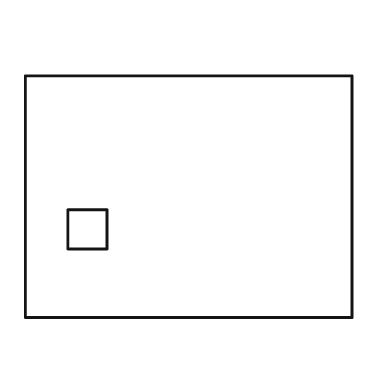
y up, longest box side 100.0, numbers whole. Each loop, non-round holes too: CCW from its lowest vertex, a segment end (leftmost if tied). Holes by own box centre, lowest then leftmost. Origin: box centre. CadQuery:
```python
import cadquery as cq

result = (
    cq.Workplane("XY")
    .moveTo(-50.0, -37.0)
    .lineTo(50.0, -37.0)
    .lineTo(50.0, 37.0)
    .lineTo(-50.0, 37.0)
    .close()
    .moveTo(-37.0, -16.0)
    .lineTo(-25.0, -16.0)
    .lineTo(-25.0, -4.0)
    .lineTo(-37.0, -4.0)
    .close()
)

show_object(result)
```